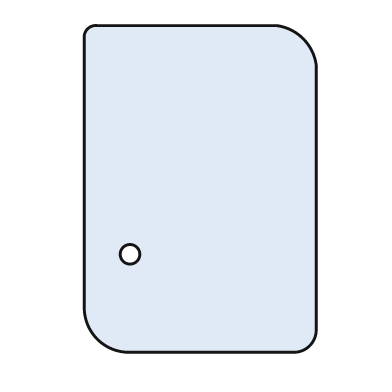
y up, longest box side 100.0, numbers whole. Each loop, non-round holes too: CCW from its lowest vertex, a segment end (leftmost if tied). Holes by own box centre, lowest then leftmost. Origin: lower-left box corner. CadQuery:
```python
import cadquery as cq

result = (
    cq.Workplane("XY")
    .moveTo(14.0, 0.0)
    .lineTo(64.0, 0.0)
    .threePointArc((69.0, 2.0), (71.0, 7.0))
    .lineTo(71.0, 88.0)
    .threePointArc((67.0, 96.0), (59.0, 100.0))
    .lineTo(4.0, 100.0)
    .threePointArc((1.0, 99.0), (0.0, 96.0))
    .lineTo(0.0, 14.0)
    .threePointArc((4.0, 4.0), (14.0, 0.0))
    .close()
    .moveTo(14.0, 30.0)
    .circle(3.0)
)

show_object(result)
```